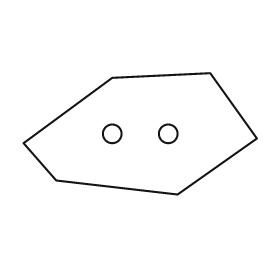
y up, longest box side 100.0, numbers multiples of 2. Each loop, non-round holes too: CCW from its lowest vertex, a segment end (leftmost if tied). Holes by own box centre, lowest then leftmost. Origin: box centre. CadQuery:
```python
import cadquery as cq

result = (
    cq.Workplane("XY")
    .moveTo(16.0, -26.0)
    .lineTo(50.0, -2.0)
    .lineTo(30.0, 26.0)
    .lineTo(-12.0, 24.0)
    .lineTo(-50.0, -4.0)
    .lineTo(-36.0, -20.0)
    .close()
    .moveTo(-12.0, 0.0)
    .circle(4.0)
    .moveTo(12.0, 0.0)
    .circle(4.0)
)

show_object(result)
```